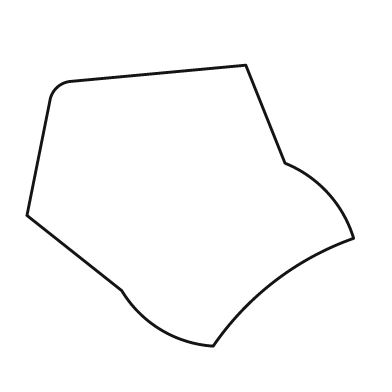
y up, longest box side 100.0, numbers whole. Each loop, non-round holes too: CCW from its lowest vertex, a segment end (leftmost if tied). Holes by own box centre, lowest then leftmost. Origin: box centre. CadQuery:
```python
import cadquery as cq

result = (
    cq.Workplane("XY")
    .moveTo(7.0, -43.0)
    .threePointArc((26.0, -23.0), (50.0, -10.0))
    .threePointArc((42.0, 4.0), (29.0, 13.0))
    .lineTo(17.0, 43.0)
    .lineTo(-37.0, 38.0)
    .threePointArc((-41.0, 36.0), (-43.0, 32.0))
    .lineTo(-50.0, -3.0)
    .lineTo(-21.0, -26.0)
    .threePointArc((-9.0, -38.0), (7.0, -43.0))
    .close()
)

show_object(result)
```